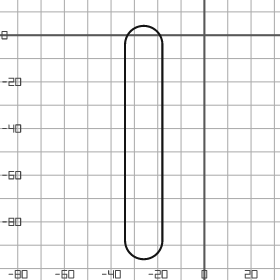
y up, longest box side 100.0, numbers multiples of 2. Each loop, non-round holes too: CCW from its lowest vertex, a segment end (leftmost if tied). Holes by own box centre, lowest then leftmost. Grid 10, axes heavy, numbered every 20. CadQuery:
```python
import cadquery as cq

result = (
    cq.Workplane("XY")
    .moveTo(-34.0, -88.0)
    .threePointArc((-26.0, -96.0), (-18.0, -88.0))
    .lineTo(-18.0, -4.0)
    .threePointArc((-26.0, 4.0), (-34.0, -4.0))
    .close()
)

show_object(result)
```